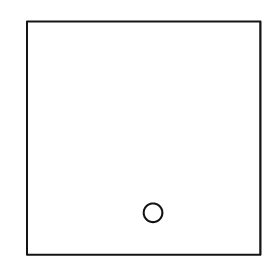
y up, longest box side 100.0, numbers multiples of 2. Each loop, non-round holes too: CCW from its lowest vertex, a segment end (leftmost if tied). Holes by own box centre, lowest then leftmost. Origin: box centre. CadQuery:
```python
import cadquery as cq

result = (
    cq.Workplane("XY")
    .moveTo(-50.0, -50.0)
    .lineTo(50.0, -50.0)
    .lineTo(50.0, 50.0)
    .lineTo(-50.0, 50.0)
    .close()
    .moveTo(4.0, -32.0)
    .circle(4.0)
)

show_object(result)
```